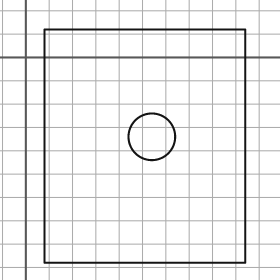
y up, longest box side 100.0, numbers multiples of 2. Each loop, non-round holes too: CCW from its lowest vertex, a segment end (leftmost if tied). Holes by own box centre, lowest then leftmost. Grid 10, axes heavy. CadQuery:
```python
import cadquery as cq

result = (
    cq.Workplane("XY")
    .moveTo(8.0, -88.0)
    .lineTo(94.0, -88.0)
    .lineTo(94.0, 12.0)
    .lineTo(8.0, 12.0)
    .close()
    .moveTo(54.0, -34.0)
    .circle(10.0)
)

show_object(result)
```